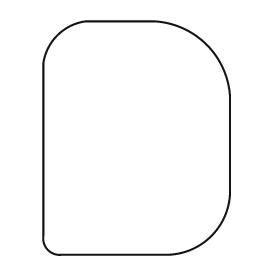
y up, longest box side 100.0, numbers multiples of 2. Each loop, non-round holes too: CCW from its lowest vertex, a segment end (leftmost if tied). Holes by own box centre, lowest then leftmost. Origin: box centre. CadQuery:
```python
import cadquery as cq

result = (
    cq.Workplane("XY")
    .moveTo(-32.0, -50.0)
    .lineTo(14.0, -50.0)
    .threePointArc((32.0, -42.0), (40.0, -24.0))
    .lineTo(40.0, 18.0)
    .threePointArc((30.0, 40.0), (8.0, 50.0))
    .lineTo(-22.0, 50.0)
    .threePointArc((-34.0, 44.0), (-40.0, 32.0))
    .lineTo(-40.0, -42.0)
    .threePointArc((-38.0, -48.0), (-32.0, -50.0))
    .close()
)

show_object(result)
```